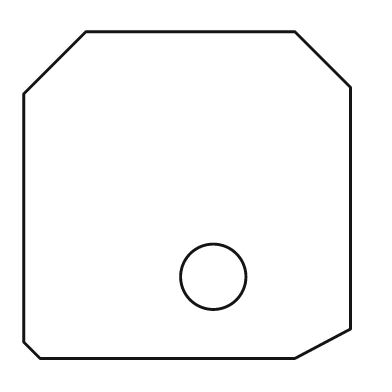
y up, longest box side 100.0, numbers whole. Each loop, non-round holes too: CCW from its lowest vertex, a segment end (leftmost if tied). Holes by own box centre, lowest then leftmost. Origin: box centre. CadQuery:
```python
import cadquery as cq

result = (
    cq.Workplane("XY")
    .moveTo(-45.0, -50.0)
    .lineTo(33.0, -50.0)
    .lineTo(50.0, -41.0)
    .lineTo(50.0, 33.0)
    .lineTo(33.0, 50.0)
    .lineTo(-31.0, 50.0)
    .lineTo(-50.0, 31.0)
    .lineTo(-50.0, -45.0)
    .close()
    .moveTo(8.0, -25.0)
    .circle(10.0)
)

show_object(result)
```